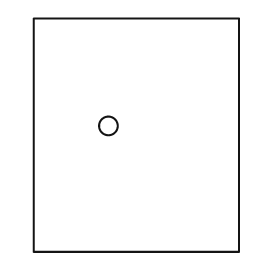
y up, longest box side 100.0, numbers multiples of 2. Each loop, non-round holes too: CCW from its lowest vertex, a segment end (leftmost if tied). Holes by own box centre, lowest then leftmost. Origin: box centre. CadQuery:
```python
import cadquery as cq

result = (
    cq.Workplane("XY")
    .moveTo(-44.0, -50.0)
    .lineTo(44.0, -50.0)
    .lineTo(44.0, 50.0)
    .lineTo(-44.0, 50.0)
    .close()
    .moveTo(-12.0, 4.0)
    .circle(4.0)
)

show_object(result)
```